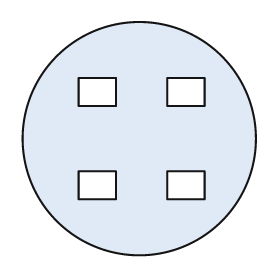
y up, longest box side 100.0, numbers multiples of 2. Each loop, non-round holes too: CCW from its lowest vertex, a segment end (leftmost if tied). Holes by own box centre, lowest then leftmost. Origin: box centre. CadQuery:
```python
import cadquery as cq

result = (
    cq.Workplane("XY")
    .moveTo(0.0, 0.0)
    .circle(50.0)
    .moveTo(-26.0, -26.0)
    .lineTo(-10.0, -26.0)
    .lineTo(-10.0, -14.0)
    .lineTo(-26.0, -14.0)
    .close()
    .moveTo(12.0, -26.0)
    .lineTo(28.0, -26.0)
    .lineTo(28.0, -14.0)
    .lineTo(12.0, -14.0)
    .close()
    .moveTo(-26.0, 14.0)
    .lineTo(-10.0, 14.0)
    .lineTo(-10.0, 26.0)
    .lineTo(-26.0, 26.0)
    .close()
    .moveTo(12.0, 14.0)
    .lineTo(28.0, 14.0)
    .lineTo(28.0, 26.0)
    .lineTo(12.0, 26.0)
    .close()
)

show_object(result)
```